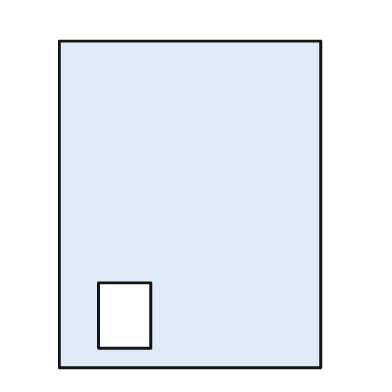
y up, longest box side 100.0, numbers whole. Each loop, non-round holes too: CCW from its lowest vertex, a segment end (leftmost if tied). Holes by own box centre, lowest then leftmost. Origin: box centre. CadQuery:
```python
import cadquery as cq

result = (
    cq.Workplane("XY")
    .moveTo(-40.0, -50.0)
    .lineTo(40.0, -50.0)
    .lineTo(40.0, 50.0)
    .lineTo(-40.0, 50.0)
    .close()
    .moveTo(-28.0, -44.0)
    .lineTo(-12.0, -44.0)
    .lineTo(-12.0, -24.0)
    .lineTo(-28.0, -24.0)
    .close()
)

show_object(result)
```